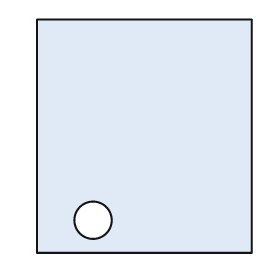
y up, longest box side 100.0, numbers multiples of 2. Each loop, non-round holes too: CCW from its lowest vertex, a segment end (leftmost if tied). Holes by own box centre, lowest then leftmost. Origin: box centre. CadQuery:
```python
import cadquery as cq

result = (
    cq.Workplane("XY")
    .moveTo(-46.0, -50.0)
    .lineTo(46.0, -50.0)
    .lineTo(46.0, 50.0)
    .lineTo(-46.0, 50.0)
    .close()
    .moveTo(-22.0, -36.0)
    .circle(8.0)
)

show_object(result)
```